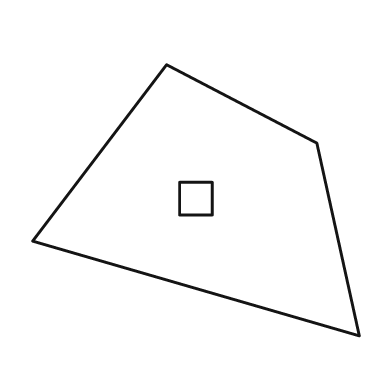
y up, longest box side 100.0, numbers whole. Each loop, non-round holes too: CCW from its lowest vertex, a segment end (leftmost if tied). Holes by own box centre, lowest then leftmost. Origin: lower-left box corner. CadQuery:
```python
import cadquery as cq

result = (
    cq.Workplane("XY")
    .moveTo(100.0, 0.0)
    .lineTo(87.0, 59.0)
    .lineTo(41.0, 83.0)
    .lineTo(0.0, 29.0)
    .close()
    .moveTo(45.0, 37.0)
    .lineTo(55.0, 37.0)
    .lineTo(55.0, 47.0)
    .lineTo(45.0, 47.0)
    .close()
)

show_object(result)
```